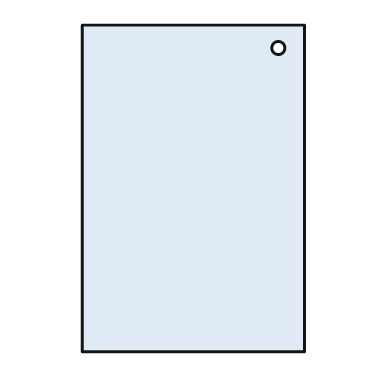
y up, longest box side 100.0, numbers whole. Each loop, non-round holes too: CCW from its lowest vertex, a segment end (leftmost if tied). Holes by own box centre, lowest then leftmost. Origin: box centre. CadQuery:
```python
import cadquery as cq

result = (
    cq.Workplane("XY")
    .moveTo(-34.0, -50.0)
    .lineTo(34.0, -50.0)
    .lineTo(34.0, 50.0)
    .lineTo(-34.0, 50.0)
    .close()
    .moveTo(26.0, 43.0)
    .circle(2.0)
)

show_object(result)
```